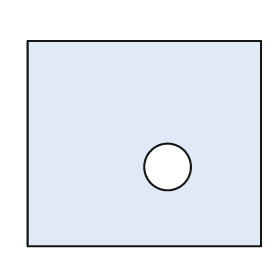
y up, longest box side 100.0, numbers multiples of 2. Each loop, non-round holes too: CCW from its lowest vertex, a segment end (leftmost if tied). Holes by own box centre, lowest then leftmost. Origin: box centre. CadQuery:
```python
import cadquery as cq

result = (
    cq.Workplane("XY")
    .moveTo(-50.0, -44.0)
    .lineTo(50.0, -44.0)
    .lineTo(50.0, 44.0)
    .lineTo(-50.0, 44.0)
    .close()
    .moveTo(10.0, -10.0)
    .circle(10.0)
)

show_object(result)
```